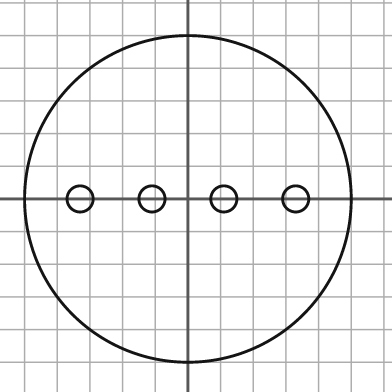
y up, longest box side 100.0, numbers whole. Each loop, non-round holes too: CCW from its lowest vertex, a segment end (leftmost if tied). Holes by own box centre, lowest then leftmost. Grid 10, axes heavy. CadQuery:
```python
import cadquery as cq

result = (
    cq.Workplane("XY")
    .moveTo(0.0, 0.0)
    .circle(50.0)
    .moveTo(-33.0, 0.0)
    .circle(4.0)
    .moveTo(-11.0, 0.0)
    .circle(4.0)
    .moveTo(11.0, 0.0)
    .circle(4.0)
    .moveTo(33.0, 0.0)
    .circle(4.0)
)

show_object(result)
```